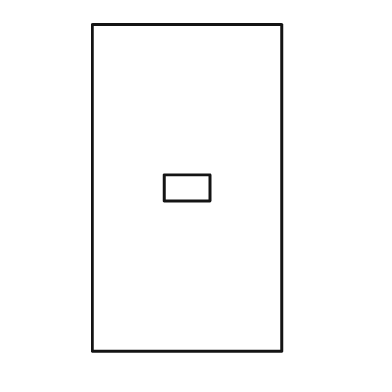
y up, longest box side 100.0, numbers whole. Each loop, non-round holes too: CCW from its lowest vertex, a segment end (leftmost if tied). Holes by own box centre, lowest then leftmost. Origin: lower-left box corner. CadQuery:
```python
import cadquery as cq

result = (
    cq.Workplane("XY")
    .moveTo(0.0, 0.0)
    .lineTo(58.0, 0.0)
    .lineTo(58.0, 100.0)
    .lineTo(0.0, 100.0)
    .close()
    .moveTo(22.0, 46.0)
    .lineTo(36.0, 46.0)
    .lineTo(36.0, 54.0)
    .lineTo(22.0, 54.0)
    .close()
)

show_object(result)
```